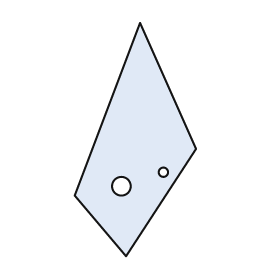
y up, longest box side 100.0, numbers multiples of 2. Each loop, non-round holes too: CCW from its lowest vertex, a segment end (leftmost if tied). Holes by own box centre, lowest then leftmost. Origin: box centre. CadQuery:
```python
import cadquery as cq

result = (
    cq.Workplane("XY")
    .moveTo(-4.0, -50.0)
    .lineTo(26.0, -4.0)
    .lineTo(2.0, 50.0)
    .lineTo(-26.0, -24.0)
    .close()
    .moveTo(-6.0, -20.0)
    .circle(4.0)
    .moveTo(12.0, -14.0)
    .circle(2.0)
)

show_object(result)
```